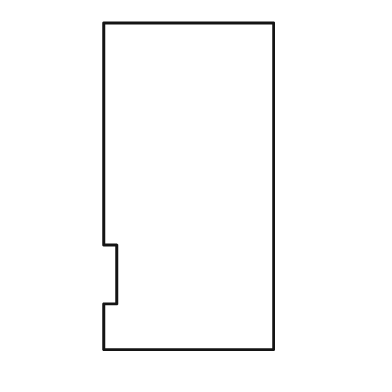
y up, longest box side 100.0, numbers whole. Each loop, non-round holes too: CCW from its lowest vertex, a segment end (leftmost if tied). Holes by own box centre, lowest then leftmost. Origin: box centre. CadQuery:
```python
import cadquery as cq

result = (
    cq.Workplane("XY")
    .moveTo(-26.0, -50.0)
    .lineTo(26.0, -50.0)
    .lineTo(26.0, 50.0)
    .lineTo(-26.0, 50.0)
    .lineTo(-26.0, -18.0)
    .lineTo(-22.0, -18.0)
    .lineTo(-22.0, -36.0)
    .lineTo(-26.0, -36.0)
    .close()
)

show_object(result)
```